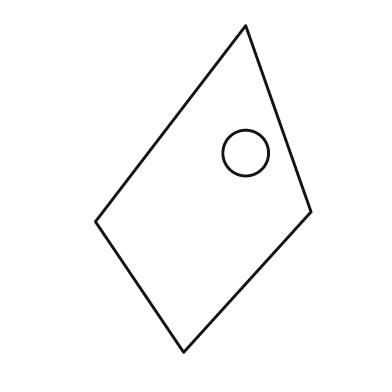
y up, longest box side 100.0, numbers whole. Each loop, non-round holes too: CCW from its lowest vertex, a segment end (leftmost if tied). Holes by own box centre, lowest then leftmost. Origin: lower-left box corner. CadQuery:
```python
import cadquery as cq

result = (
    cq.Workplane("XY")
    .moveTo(27.0, 0.0)
    .lineTo(66.0, 43.0)
    .lineTo(46.0, 100.0)
    .lineTo(0.0, 40.0)
    .close()
    .moveTo(46.0, 61.0)
    .circle(7.0)
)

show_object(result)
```